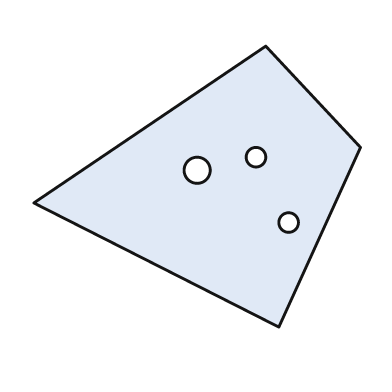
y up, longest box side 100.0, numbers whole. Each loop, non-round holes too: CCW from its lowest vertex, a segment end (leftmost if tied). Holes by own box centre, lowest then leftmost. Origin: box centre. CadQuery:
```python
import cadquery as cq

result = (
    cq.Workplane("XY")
    .moveTo(25.0, -43.0)
    .lineTo(50.0, 12.0)
    .lineTo(21.0, 43.0)
    .lineTo(-50.0, -5.0)
    .close()
    .moveTo(28.0, -11.0)
    .circle(3.0)
    .moveTo(0.0, 5.0)
    .circle(4.0)
    .moveTo(18.0, 9.0)
    .circle(3.0)
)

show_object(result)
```